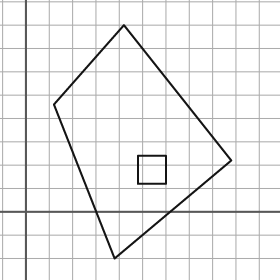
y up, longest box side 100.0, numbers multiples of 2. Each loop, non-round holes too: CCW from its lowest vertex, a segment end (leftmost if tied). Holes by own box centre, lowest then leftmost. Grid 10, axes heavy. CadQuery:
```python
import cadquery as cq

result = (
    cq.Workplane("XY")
    .moveTo(38.0, -20.0)
    .lineTo(88.0, 22.0)
    .lineTo(42.0, 80.0)
    .lineTo(12.0, 46.0)
    .close()
    .moveTo(48.0, 12.0)
    .lineTo(60.0, 12.0)
    .lineTo(60.0, 24.0)
    .lineTo(48.0, 24.0)
    .close()
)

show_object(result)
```